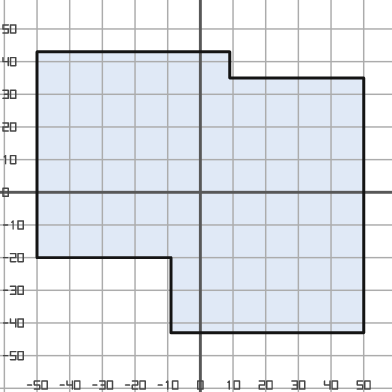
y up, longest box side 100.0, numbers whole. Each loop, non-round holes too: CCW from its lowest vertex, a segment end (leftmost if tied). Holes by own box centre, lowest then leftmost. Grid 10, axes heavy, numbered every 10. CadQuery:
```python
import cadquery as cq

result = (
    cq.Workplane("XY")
    .moveTo(-9.0, -43.0)
    .lineTo(50.0, -43.0)
    .lineTo(50.0, 35.0)
    .lineTo(9.0, 35.0)
    .lineTo(9.0, 43.0)
    .lineTo(-50.0, 43.0)
    .lineTo(-50.0, -20.0)
    .lineTo(-9.0, -20.0)
    .close()
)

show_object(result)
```